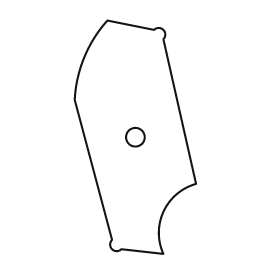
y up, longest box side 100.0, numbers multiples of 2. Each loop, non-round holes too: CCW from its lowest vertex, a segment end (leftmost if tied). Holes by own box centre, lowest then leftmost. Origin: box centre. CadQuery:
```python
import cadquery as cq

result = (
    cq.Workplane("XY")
    .moveTo(12.0, -50.0)
    .threePointArc((12.0, -32.0), (26.0, -20.0))
    .lineTo(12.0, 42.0)
    .threePointArc((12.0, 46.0), (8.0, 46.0))
    .lineTo(-12.0, 50.0)
    .threePointArc((-22.0, 34.0), (-26.0, 16.0))
    .lineTo(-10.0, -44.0)
    .threePointArc((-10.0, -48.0), (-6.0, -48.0))
    .close()
    .moveTo(0.0, 0.0)
    .circle(4.0)
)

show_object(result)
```